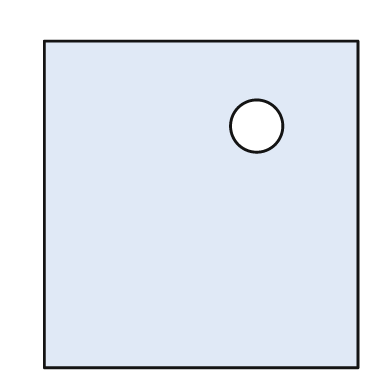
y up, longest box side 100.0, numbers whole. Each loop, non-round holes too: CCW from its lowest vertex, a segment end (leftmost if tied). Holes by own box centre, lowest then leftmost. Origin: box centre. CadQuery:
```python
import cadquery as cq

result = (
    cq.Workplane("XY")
    .moveTo(-48.0, -50.0)
    .lineTo(48.0, -50.0)
    .lineTo(48.0, 50.0)
    .lineTo(-48.0, 50.0)
    .close()
    .moveTo(17.0, 24.0)
    .circle(8.0)
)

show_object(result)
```